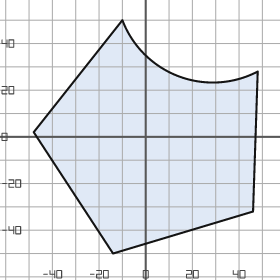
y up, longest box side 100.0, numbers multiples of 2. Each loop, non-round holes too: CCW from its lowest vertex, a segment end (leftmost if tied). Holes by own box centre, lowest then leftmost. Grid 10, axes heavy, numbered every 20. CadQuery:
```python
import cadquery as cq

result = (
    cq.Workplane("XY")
    .moveTo(-14.0, -50.0)
    .lineTo(46.0, -32.0)
    .lineTo(48.0, 28.0)
    .threePointArc((14.0, 26.0), (-10.0, 50.0))
    .lineTo(-48.0, 2.0)
    .close()
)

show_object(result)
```